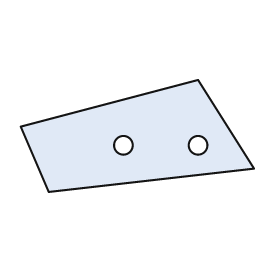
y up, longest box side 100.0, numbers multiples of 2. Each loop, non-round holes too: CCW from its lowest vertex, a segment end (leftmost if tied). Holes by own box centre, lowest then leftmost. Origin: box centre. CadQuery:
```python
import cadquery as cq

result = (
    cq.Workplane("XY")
    .moveTo(-38.0, -24.0)
    .lineTo(50.0, -14.0)
    .lineTo(26.0, 24.0)
    .lineTo(-50.0, 4.0)
    .close()
    .moveTo(-6.0, -4.0)
    .circle(4.0)
    .moveTo(26.0, -4.0)
    .circle(4.0)
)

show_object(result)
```